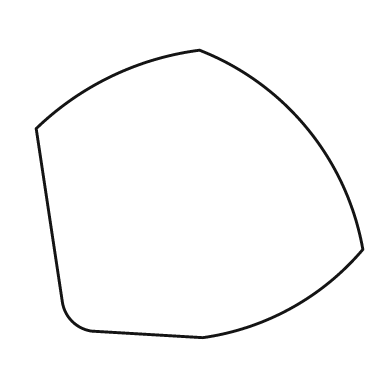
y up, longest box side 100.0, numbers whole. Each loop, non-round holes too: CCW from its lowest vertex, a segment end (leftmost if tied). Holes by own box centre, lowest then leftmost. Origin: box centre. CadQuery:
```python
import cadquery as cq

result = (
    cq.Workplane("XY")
    .moveTo(1.0, -44.0)
    .threePointArc((28.0, -35.0), (50.0, -17.0))
    .threePointArc((33.0, 20.0), (0.0, 44.0))
    .threePointArc((-27.0, 36.0), (-50.0, 20.0))
    .lineTo(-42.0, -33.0)
    .threePointArc((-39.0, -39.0), (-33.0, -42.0))
    .close()
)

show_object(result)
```